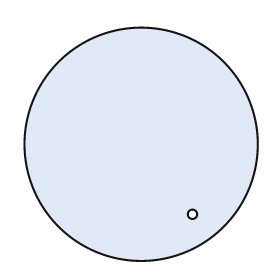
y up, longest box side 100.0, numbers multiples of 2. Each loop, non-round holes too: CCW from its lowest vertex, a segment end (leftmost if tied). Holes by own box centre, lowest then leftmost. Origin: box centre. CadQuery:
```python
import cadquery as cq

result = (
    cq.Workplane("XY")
    .moveTo(0.0, 0.0)
    .circle(50.0)
    .moveTo(22.0, -30.0)
    .circle(2.0)
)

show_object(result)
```